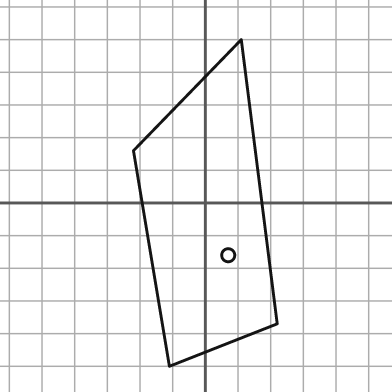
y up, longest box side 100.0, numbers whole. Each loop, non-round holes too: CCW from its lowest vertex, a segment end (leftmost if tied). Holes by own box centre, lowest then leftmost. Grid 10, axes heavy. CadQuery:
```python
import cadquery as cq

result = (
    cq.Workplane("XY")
    .moveTo(-11.0, -50.0)
    .lineTo(22.0, -37.0)
    .lineTo(11.0, 50.0)
    .lineTo(-22.0, 16.0)
    .close()
    .moveTo(7.0, -16.0)
    .circle(2.0)
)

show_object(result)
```